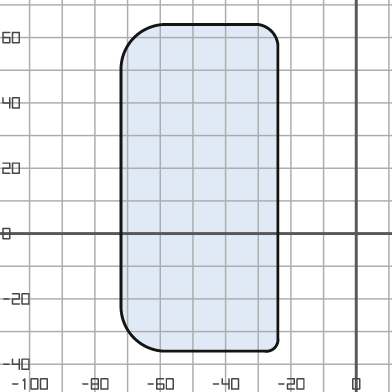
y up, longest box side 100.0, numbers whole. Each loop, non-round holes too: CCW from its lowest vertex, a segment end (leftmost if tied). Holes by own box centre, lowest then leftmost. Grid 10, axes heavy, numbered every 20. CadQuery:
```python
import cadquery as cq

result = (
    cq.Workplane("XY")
    .moveTo(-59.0, -36.0)
    .lineTo(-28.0, -36.0)
    .threePointArc((-25.0, -35.0), (-24.0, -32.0))
    .lineTo(-24.0, 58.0)
    .threePointArc((-26.0, 62.0), (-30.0, 64.0))
    .lineTo(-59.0, 64.0)
    .threePointArc((-68.0, 60.0), (-72.0, 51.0))
    .lineTo(-72.0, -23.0)
    .threePointArc((-68.0, -32.0), (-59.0, -36.0))
    .close()
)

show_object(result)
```